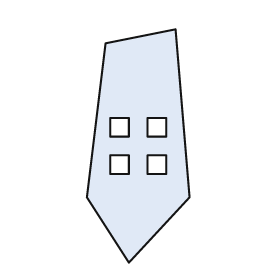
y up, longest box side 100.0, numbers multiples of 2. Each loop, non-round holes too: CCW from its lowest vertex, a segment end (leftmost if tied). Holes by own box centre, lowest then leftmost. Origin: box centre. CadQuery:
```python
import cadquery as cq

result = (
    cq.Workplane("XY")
    .moveTo(-4.0, -50.0)
    .lineTo(22.0, -22.0)
    .lineTo(16.0, 50.0)
    .lineTo(-14.0, 44.0)
    .lineTo(-22.0, -22.0)
    .close()
    .moveTo(-12.0, -12.0)
    .lineTo(-4.0, -12.0)
    .lineTo(-4.0, -4.0)
    .lineTo(-12.0, -4.0)
    .close()
    .moveTo(4.0, -12.0)
    .lineTo(12.0, -12.0)
    .lineTo(12.0, -4.0)
    .lineTo(4.0, -4.0)
    .close()
    .moveTo(-12.0, 4.0)
    .lineTo(-4.0, 4.0)
    .lineTo(-4.0, 12.0)
    .lineTo(-12.0, 12.0)
    .close()
    .moveTo(4.0, 4.0)
    .lineTo(12.0, 4.0)
    .lineTo(12.0, 12.0)
    .lineTo(4.0, 12.0)
    .close()
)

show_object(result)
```